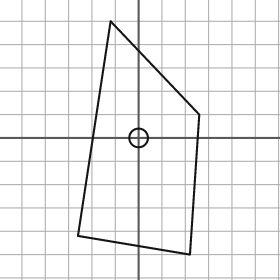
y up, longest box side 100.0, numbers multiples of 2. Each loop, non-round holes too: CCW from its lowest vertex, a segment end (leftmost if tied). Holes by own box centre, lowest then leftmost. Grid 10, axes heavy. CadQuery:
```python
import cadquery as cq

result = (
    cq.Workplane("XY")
    .moveTo(22.0, -50.0)
    .lineTo(26.0, 10.0)
    .lineTo(-12.0, 50.0)
    .lineTo(-26.0, -42.0)
    .close()
    .moveTo(0.0, 0.0)
    .circle(4.0)
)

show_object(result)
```